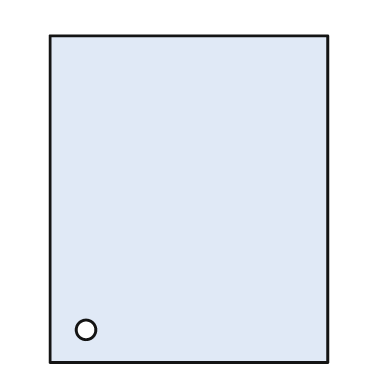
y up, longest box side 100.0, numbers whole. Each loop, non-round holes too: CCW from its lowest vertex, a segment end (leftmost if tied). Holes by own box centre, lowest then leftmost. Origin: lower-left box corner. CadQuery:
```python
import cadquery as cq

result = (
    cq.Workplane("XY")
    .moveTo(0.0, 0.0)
    .lineTo(85.0, 0.0)
    .lineTo(85.0, 100.0)
    .lineTo(0.0, 100.0)
    .close()
    .moveTo(11.0, 10.0)
    .circle(3.0)
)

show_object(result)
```